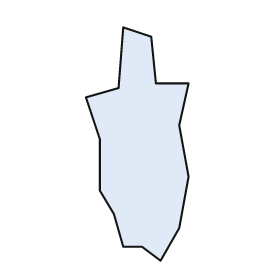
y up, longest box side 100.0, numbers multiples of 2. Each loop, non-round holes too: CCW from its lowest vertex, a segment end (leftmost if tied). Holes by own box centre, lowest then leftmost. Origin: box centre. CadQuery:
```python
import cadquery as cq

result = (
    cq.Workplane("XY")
    .moveTo(10.0, -50.0)
    .lineTo(18.0, -36.0)
    .lineTo(22.0, -14.0)
    .lineTo(18.0, 8.0)
    .lineTo(22.0, 26.0)
    .lineTo(8.0, 26.0)
    .lineTo(6.0, 46.0)
    .lineTo(-6.0, 50.0)
    .lineTo(-8.0, 24.0)
    .lineTo(-22.0, 20.0)
    .lineTo(-16.0, 2.0)
    .lineTo(-16.0, -20.0)
    .lineTo(-10.0, -30.0)
    .lineTo(-6.0, -44.0)
    .lineTo(2.0, -44.0)
    .close()
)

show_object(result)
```